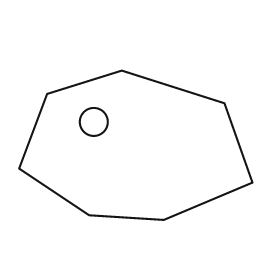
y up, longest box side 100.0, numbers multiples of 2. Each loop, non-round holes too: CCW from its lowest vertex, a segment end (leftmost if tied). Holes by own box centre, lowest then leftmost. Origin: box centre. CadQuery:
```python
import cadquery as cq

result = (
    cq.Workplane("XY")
    .moveTo(12.0, -32.0)
    .lineTo(50.0, -16.0)
    .lineTo(38.0, 18.0)
    .lineTo(-6.0, 32.0)
    .lineTo(-38.0, 22.0)
    .lineTo(-50.0, -10.0)
    .lineTo(-20.0, -30.0)
    .close()
    .moveTo(-18.0, 10.0)
    .circle(6.0)
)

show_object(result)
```